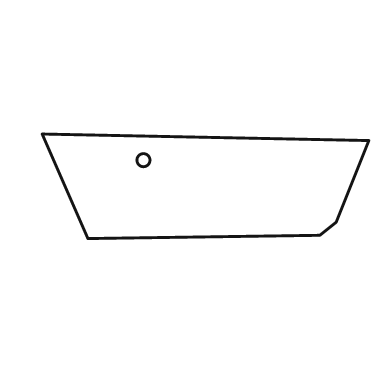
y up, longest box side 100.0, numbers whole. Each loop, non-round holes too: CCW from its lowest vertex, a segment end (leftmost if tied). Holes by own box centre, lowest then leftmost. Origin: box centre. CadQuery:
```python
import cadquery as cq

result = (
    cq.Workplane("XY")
    .moveTo(-36.0, -16.0)
    .lineTo(35.0, -15.0)
    .lineTo(40.0, -11.0)
    .lineTo(50.0, 14.0)
    .lineTo(-50.0, 16.0)
    .close()
    .moveTo(-19.0, 8.0)
    .circle(2.0)
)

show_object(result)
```